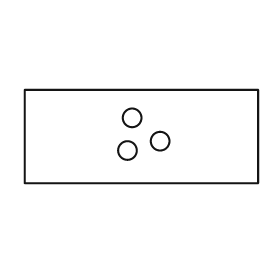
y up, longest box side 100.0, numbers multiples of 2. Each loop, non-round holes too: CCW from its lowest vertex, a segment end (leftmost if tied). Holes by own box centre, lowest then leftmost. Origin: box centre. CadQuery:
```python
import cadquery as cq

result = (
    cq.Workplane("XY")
    .moveTo(-50.0, -20.0)
    .lineTo(50.0, -20.0)
    .lineTo(50.0, 20.0)
    .lineTo(-50.0, 20.0)
    .close()
    .moveTo(-6.0, -6.0)
    .circle(4.0)
    .moveTo(8.0, -2.0)
    .circle(4.0)
    .moveTo(-4.0, 8.0)
    .circle(4.0)
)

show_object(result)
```